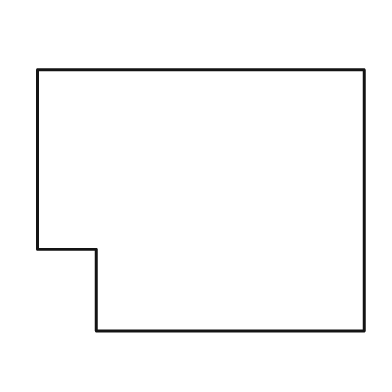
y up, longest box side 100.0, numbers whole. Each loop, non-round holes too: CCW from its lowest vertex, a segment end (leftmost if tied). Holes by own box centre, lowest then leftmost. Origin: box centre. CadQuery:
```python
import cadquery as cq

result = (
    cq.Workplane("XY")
    .moveTo(-32.0, -40.0)
    .lineTo(50.0, -40.0)
    .lineTo(50.0, 40.0)
    .lineTo(-50.0, 40.0)
    .lineTo(-50.0, -15.0)
    .lineTo(-32.0, -15.0)
    .close()
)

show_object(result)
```